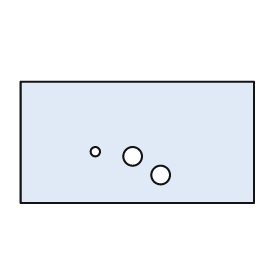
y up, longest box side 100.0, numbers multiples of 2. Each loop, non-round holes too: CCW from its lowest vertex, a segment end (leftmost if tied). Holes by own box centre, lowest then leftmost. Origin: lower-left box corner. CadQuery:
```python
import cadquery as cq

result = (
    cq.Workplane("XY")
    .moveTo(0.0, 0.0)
    .lineTo(100.0, 0.0)
    .lineTo(100.0, 52.0)
    .lineTo(0.0, 52.0)
    .close()
    .moveTo(60.0, 12.0)
    .circle(4.0)
    .moveTo(48.0, 20.0)
    .circle(4.0)
    .moveTo(32.0, 22.0)
    .circle(2.0)
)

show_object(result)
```